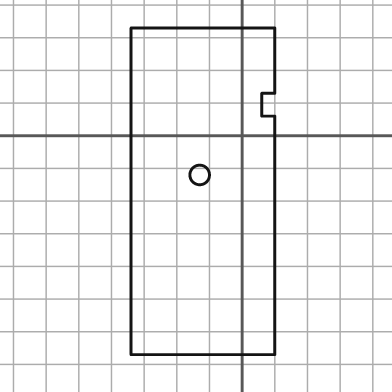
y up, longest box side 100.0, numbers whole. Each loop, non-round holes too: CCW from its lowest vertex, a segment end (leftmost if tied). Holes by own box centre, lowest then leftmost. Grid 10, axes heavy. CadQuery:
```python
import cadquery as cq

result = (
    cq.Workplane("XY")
    .moveTo(-34.0, -67.0)
    .lineTo(10.0, -67.0)
    .lineTo(10.0, 6.0)
    .lineTo(6.0, 6.0)
    .lineTo(6.0, 13.0)
    .lineTo(10.0, 13.0)
    .lineTo(10.0, 33.0)
    .lineTo(-34.0, 33.0)
    .close()
    .moveTo(-13.0, -12.0)
    .circle(3.0)
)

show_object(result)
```